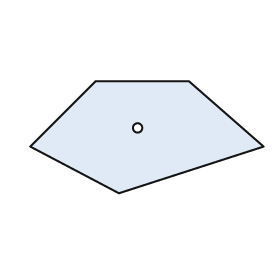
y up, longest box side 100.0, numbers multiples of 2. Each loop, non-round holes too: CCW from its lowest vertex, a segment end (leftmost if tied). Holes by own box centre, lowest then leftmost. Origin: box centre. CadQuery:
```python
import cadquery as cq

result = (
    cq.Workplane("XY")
    .moveTo(-12.0, -24.0)
    .lineTo(50.0, -4.0)
    .lineTo(18.0, 24.0)
    .lineTo(-22.0, 24.0)
    .lineTo(-50.0, -4.0)
    .close()
    .moveTo(-4.0, 4.0)
    .circle(2.0)
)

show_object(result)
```